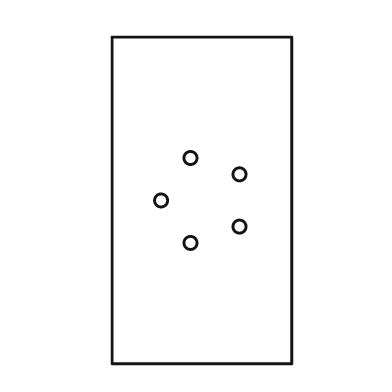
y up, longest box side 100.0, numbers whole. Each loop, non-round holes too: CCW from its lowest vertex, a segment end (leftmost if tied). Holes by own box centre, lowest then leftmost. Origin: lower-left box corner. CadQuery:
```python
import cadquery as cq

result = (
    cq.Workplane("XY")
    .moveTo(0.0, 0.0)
    .lineTo(55.0, 0.0)
    .lineTo(55.0, 100.0)
    .lineTo(0.0, 100.0)
    .close()
    .moveTo(24.0, 37.0)
    .circle(2.0)
    .moveTo(39.0, 42.0)
    .circle(2.0)
    .moveTo(15.0, 50.0)
    .circle(2.0)
    .moveTo(39.0, 58.0)
    .circle(2.0)
    .moveTo(24.0, 63.0)
    .circle(2.0)
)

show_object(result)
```